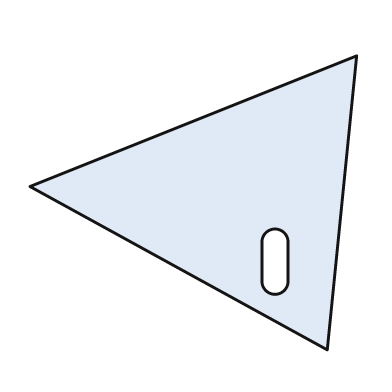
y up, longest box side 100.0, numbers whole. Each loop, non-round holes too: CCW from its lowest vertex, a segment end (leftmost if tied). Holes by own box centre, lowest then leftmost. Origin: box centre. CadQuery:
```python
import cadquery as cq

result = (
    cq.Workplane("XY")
    .moveTo(41.0, -45.0)
    .lineTo(50.0, 45.0)
    .lineTo(-50.0, 5.0)
    .close()
    .moveTo(21.0, -24.0)
    .threePointArc((25.0, -28.0), (29.0, -24.0))
    .lineTo(29.0, -12.0)
    .threePointArc((25.0, -8.0), (21.0, -12.0))
    .close()
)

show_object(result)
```